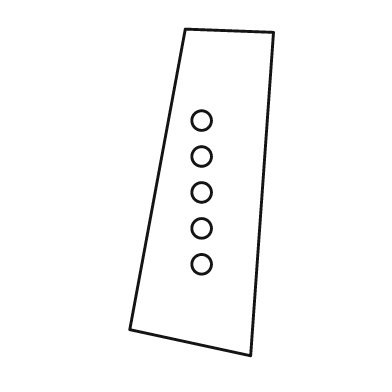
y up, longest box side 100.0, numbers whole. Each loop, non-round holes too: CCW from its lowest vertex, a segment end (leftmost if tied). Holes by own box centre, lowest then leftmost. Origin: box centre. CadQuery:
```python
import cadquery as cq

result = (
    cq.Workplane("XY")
    .moveTo(15.0, -50.0)
    .lineTo(22.0, 49.0)
    .lineTo(-5.0, 50.0)
    .lineTo(-22.0, -42.0)
    .close()
    .moveTo(0.0, -22.0)
    .circle(3.0)
    .moveTo(0.0, -11.0)
    .circle(3.0)
    .moveTo(0.0, 0.0)
    .circle(3.0)
    .moveTo(0.0, 11.0)
    .circle(3.0)
    .moveTo(0.0, 22.0)
    .circle(3.0)
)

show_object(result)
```